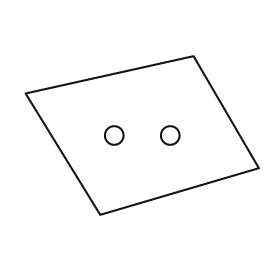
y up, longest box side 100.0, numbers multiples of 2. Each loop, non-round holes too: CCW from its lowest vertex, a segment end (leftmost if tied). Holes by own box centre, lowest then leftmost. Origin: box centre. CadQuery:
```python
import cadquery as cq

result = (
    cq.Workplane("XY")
    .moveTo(-18.0, -34.0)
    .lineTo(50.0, -14.0)
    .lineTo(22.0, 34.0)
    .lineTo(-50.0, 18.0)
    .close()
    .moveTo(-12.0, 0.0)
    .circle(4.0)
    .moveTo(12.0, 0.0)
    .circle(4.0)
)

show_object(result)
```